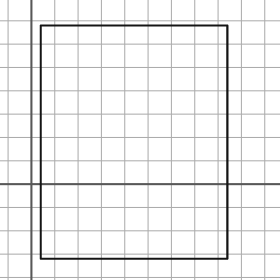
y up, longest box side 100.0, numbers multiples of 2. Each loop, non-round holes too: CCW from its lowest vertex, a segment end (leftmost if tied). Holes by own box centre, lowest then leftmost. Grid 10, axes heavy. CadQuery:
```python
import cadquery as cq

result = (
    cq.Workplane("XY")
    .moveTo(4.0, -32.0)
    .lineTo(84.0, -32.0)
    .lineTo(84.0, 68.0)
    .lineTo(4.0, 68.0)
    .close()
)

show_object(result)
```